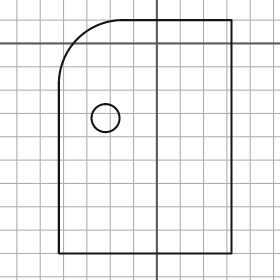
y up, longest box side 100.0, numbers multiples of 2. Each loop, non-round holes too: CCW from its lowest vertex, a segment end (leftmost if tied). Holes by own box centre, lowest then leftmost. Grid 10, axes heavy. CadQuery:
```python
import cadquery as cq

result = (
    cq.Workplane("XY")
    .moveTo(-42.0, -90.0)
    .lineTo(32.0, -90.0)
    .lineTo(32.0, 10.0)
    .lineTo(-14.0, 10.0)
    .threePointArc((-34.0, 2.0), (-42.0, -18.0))
    .close()
    .moveTo(-22.0, -32.0)
    .circle(6.0)
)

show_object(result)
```